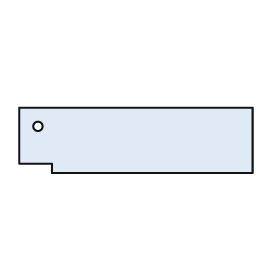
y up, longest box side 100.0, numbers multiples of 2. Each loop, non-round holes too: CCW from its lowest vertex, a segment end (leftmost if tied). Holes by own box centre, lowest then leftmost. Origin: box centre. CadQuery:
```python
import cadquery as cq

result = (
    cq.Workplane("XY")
    .moveTo(-36.0, -14.0)
    .lineTo(50.0, -14.0)
    .lineTo(50.0, 14.0)
    .lineTo(-50.0, 14.0)
    .lineTo(-50.0, -10.0)
    .lineTo(-36.0, -10.0)
    .close()
    .moveTo(-42.0, 6.0)
    .circle(2.0)
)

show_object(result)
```